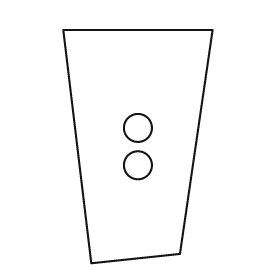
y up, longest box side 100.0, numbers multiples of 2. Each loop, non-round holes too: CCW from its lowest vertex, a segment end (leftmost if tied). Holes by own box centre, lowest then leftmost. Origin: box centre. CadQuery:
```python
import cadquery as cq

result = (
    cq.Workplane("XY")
    .moveTo(-20.0, -50.0)
    .lineTo(18.0, -46.0)
    .lineTo(32.0, 50.0)
    .lineTo(-32.0, 50.0)
    .close()
    .moveTo(0.0, -8.0)
    .circle(6.0)
    .moveTo(0.0, 8.0)
    .circle(6.0)
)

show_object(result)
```